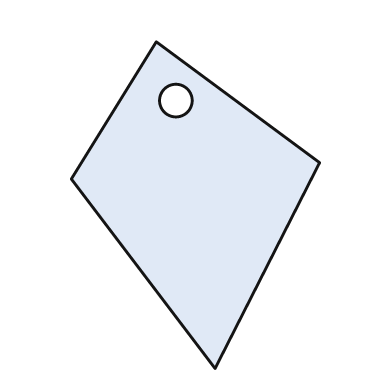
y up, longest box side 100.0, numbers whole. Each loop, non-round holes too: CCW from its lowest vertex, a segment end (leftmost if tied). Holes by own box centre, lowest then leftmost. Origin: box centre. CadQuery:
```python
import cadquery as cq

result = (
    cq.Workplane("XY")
    .moveTo(6.0, -50.0)
    .lineTo(38.0, 13.0)
    .lineTo(-12.0, 50.0)
    .lineTo(-38.0, 8.0)
    .close()
    .moveTo(-6.0, 32.0)
    .circle(5.0)
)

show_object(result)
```